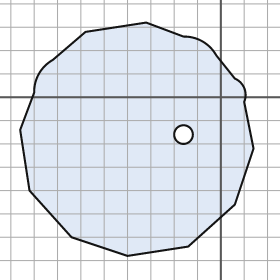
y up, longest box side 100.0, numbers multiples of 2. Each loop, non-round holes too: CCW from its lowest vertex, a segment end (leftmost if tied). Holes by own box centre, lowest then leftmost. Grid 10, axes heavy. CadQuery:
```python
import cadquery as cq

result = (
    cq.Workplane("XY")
    .moveTo(-40.0, -68.0)
    .lineTo(-14.0, -64.0)
    .lineTo(6.0, -46.0)
    .lineTo(14.0, -22.0)
    .lineTo(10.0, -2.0)
    .threePointArc((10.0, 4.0), (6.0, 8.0))
    .lineTo(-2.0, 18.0)
    .threePointArc((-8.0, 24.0), (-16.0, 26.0))
    .lineTo(-32.0, 32.0)
    .lineTo(-58.0, 28.0)
    .lineTo(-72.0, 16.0)
    .threePointArc((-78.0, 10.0), (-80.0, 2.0))
    .lineTo(-86.0, -14.0)
    .lineTo(-82.0, -40.0)
    .lineTo(-64.0, -60.0)
    .close()
    .moveTo(-16.0, -16.0)
    .circle(4.0)
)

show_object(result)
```